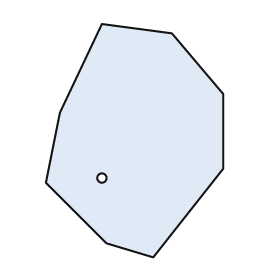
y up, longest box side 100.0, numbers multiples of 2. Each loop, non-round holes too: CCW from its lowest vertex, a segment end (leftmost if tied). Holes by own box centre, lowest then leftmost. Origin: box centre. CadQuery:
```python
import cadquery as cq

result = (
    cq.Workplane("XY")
    .moveTo(8.0, -50.0)
    .lineTo(38.0, -12.0)
    .lineTo(38.0, 20.0)
    .lineTo(16.0, 46.0)
    .lineTo(-14.0, 50.0)
    .lineTo(-32.0, 12.0)
    .lineTo(-38.0, -18.0)
    .lineTo(-12.0, -44.0)
    .close()
    .moveTo(-14.0, -16.0)
    .circle(2.0)
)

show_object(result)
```